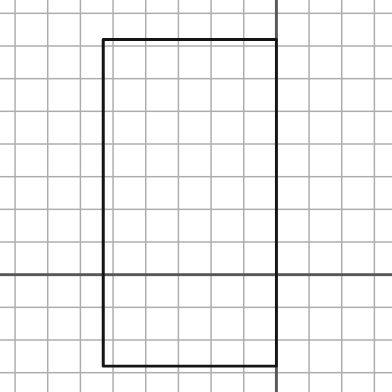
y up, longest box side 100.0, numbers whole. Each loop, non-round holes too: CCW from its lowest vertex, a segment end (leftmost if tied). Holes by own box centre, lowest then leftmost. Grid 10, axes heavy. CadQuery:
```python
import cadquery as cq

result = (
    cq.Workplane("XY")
    .moveTo(-53.0, -28.0)
    .lineTo(0.0, -28.0)
    .lineTo(0.0, 72.0)
    .lineTo(-53.0, 72.0)
    .close()
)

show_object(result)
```